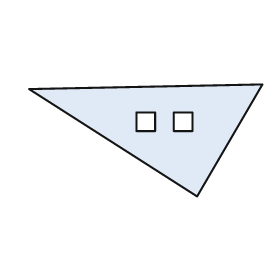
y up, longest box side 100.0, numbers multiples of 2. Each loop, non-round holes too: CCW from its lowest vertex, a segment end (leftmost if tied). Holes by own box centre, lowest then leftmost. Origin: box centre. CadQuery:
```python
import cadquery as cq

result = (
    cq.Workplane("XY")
    .moveTo(22.0, -24.0)
    .lineTo(50.0, 24.0)
    .lineTo(-50.0, 22.0)
    .close()
    .moveTo(-4.0, 4.0)
    .lineTo(4.0, 4.0)
    .lineTo(4.0, 12.0)
    .lineTo(-4.0, 12.0)
    .close()
    .moveTo(12.0, 4.0)
    .lineTo(20.0, 4.0)
    .lineTo(20.0, 12.0)
    .lineTo(12.0, 12.0)
    .close()
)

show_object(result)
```